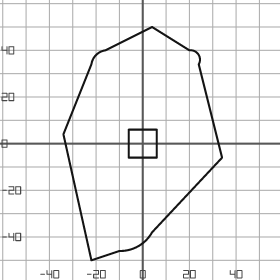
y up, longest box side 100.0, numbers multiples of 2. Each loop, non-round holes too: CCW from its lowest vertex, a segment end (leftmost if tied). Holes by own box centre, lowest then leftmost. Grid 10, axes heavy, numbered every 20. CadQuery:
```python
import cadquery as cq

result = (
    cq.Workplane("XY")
    .moveTo(-22.0, -50.0)
    .lineTo(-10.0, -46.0)
    .threePointArc((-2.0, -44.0), (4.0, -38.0))
    .lineTo(34.0, -6.0)
    .lineTo(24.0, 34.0)
    .threePointArc((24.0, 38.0), (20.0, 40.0))
    .lineTo(4.0, 50.0)
    .lineTo(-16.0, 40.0)
    .threePointArc((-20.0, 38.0), (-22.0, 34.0))
    .lineTo(-34.0, 4.0)
    .close()
    .moveTo(-6.0, -6.0)
    .lineTo(6.0, -6.0)
    .lineTo(6.0, 6.0)
    .lineTo(-6.0, 6.0)
    .close()
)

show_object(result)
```